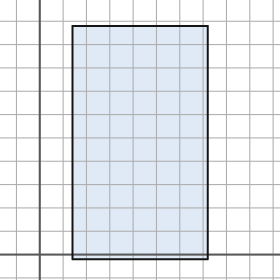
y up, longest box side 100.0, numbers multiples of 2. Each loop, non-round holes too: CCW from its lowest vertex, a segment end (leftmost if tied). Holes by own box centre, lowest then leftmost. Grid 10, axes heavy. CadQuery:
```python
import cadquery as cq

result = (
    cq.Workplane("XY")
    .moveTo(14.0, -2.0)
    .lineTo(72.0, -2.0)
    .lineTo(72.0, 98.0)
    .lineTo(14.0, 98.0)
    .close()
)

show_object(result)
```